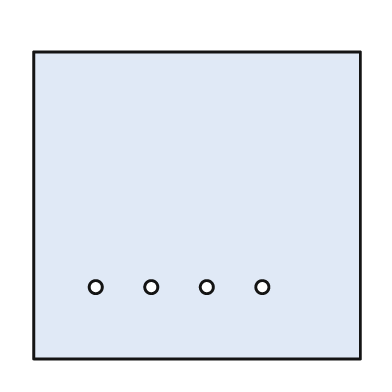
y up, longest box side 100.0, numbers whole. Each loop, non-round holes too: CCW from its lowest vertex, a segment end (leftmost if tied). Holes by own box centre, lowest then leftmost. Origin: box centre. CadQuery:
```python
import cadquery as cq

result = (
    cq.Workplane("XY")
    .moveTo(-50.0, -47.0)
    .lineTo(50.0, -47.0)
    .lineTo(50.0, 47.0)
    .lineTo(-50.0, 47.0)
    .close()
    .moveTo(-31.0, -25.0)
    .circle(2.0)
    .moveTo(-14.0, -25.0)
    .circle(2.0)
    .moveTo(3.0, -25.0)
    .circle(2.0)
    .moveTo(20.0, -25.0)
    .circle(2.0)
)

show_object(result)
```